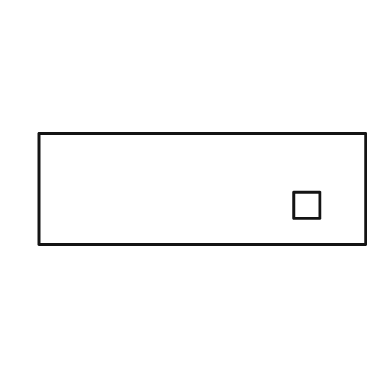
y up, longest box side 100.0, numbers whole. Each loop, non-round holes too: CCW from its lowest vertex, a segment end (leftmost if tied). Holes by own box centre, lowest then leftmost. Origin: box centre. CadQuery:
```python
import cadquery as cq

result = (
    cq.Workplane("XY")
    .moveTo(-50.0, -17.0)
    .lineTo(50.0, -17.0)
    .lineTo(50.0, 17.0)
    .lineTo(-50.0, 17.0)
    .close()
    .moveTo(28.0, -9.0)
    .lineTo(36.0, -9.0)
    .lineTo(36.0, -1.0)
    .lineTo(28.0, -1.0)
    .close()
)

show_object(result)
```